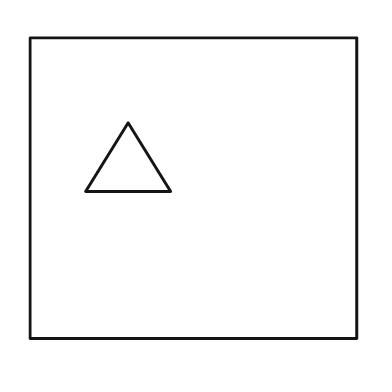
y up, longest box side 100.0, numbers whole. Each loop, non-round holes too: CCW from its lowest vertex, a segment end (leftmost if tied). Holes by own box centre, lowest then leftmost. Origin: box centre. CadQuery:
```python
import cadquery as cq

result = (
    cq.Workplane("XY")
    .moveTo(-50.0, -46.0)
    .lineTo(50.0, -46.0)
    .lineTo(50.0, 46.0)
    .lineTo(-50.0, 46.0)
    .close()
    .moveTo(-33.0, -1.0)
    .lineTo(-7.0, -1.0)
    .lineTo(-20.0, 20.0)
    .close()
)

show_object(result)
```